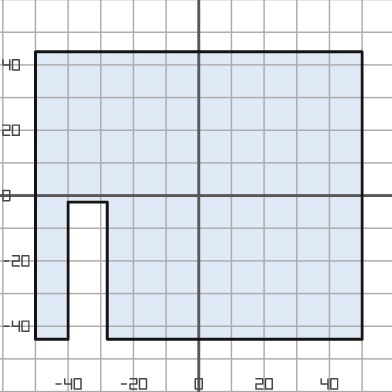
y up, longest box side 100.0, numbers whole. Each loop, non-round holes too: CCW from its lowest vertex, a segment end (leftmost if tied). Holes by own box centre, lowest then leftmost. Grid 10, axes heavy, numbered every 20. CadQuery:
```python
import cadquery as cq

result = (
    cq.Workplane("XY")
    .moveTo(-50.0, -44.0)
    .lineTo(-40.0, -44.0)
    .lineTo(-40.0, -2.0)
    .lineTo(-28.0, -2.0)
    .lineTo(-28.0, -44.0)
    .lineTo(50.0, -44.0)
    .lineTo(50.0, 44.0)
    .lineTo(-50.0, 44.0)
    .close()
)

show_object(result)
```